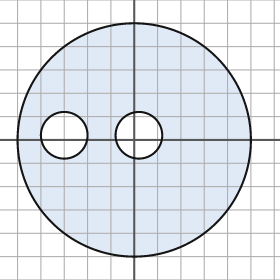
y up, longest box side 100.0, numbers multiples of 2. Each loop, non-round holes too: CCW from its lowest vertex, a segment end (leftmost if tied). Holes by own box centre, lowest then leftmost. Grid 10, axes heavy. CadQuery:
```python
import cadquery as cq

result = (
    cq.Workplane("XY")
    .moveTo(0.0, 0.0)
    .circle(50.0)
    .moveTo(-30.0, 2.0)
    .circle(10.0)
    .moveTo(2.0, 2.0)
    .circle(10.0)
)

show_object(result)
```